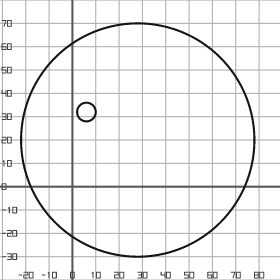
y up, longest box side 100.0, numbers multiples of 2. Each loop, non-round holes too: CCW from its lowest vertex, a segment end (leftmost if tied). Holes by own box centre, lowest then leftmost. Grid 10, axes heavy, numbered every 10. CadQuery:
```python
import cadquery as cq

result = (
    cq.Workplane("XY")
    .moveTo(28.0, 20.0)
    .circle(50.0)
    .moveTo(6.0, 32.0)
    .circle(4.0)
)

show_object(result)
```